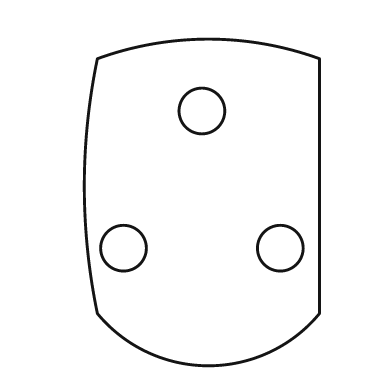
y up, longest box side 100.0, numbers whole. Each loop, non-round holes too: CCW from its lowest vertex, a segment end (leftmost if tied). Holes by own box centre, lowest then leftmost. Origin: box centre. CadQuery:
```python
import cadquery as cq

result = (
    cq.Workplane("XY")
    .moveTo(-32.0, -34.0)
    .threePointArc((2.0, -50.0), (36.0, -34.0))
    .lineTo(36.0, 44.0)
    .threePointArc((2.0, 50.0), (-32.0, 44.0))
    .threePointArc((-36.0, 5.0), (-32.0, -34.0))
    .close()
    .moveTo(-24.0, -14.0)
    .circle(7.0)
    .moveTo(24.0, -14.0)
    .circle(7.0)
    .moveTo(0.0, 28.0)
    .circle(7.0)
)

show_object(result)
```